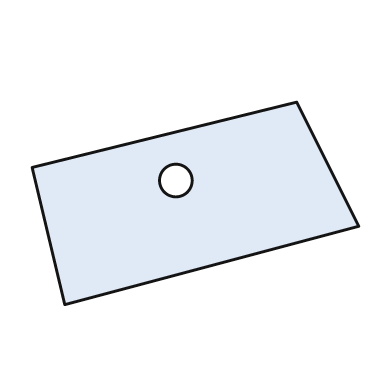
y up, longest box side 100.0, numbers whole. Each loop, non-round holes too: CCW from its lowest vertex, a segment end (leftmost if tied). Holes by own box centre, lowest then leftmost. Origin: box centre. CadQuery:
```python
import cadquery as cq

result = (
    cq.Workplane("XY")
    .moveTo(-40.0, -31.0)
    .lineTo(50.0, -7.0)
    .lineTo(31.0, 31.0)
    .lineTo(-50.0, 11.0)
    .close()
    .moveTo(-6.0, 7.0)
    .circle(5.0)
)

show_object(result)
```